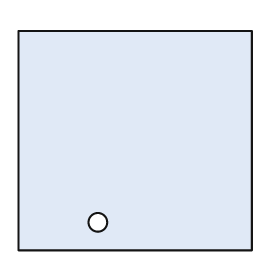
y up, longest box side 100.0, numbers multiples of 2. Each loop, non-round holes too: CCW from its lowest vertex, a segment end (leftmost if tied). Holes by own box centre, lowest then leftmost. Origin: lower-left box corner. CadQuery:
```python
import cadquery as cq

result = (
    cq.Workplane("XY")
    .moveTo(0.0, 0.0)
    .lineTo(100.0, 0.0)
    .lineTo(100.0, 94.0)
    .lineTo(0.0, 94.0)
    .close()
    .moveTo(34.0, 12.0)
    .circle(4.0)
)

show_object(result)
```